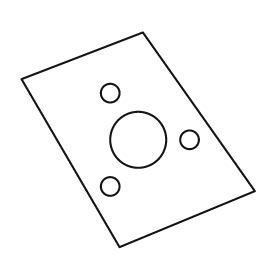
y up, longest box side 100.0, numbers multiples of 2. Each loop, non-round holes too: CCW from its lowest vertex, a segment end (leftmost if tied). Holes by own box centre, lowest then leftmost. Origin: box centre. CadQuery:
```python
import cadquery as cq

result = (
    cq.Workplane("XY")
    .moveTo(-8.0, -46.0)
    .lineTo(50.0, -22.0)
    .lineTo(2.0, 46.0)
    .lineTo(-50.0, 26.0)
    .close()
    .moveTo(-12.0, -20.0)
    .circle(4.0)
    .moveTo(0.0, 0.0)
    .circle(12.0)
    .moveTo(22.0, 0.0)
    .circle(4.0)
    .moveTo(-12.0, 20.0)
    .circle(4.0)
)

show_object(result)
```